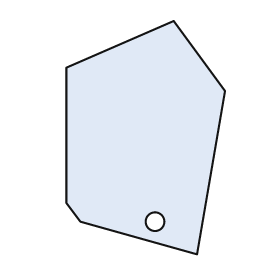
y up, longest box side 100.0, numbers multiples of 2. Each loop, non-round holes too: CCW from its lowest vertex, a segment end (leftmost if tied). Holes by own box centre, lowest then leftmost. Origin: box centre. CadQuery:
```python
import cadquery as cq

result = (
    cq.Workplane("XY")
    .moveTo(22.0, -50.0)
    .lineTo(34.0, 20.0)
    .lineTo(12.0, 50.0)
    .lineTo(-34.0, 30.0)
    .lineTo(-34.0, -28.0)
    .lineTo(-28.0, -36.0)
    .close()
    .moveTo(4.0, -36.0)
    .circle(4.0)
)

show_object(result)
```